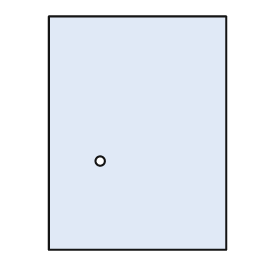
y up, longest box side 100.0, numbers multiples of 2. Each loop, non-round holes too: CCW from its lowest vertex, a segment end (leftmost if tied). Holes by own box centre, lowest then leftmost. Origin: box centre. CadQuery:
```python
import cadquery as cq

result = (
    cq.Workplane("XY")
    .moveTo(-38.0, -50.0)
    .lineTo(38.0, -50.0)
    .lineTo(38.0, 50.0)
    .lineTo(-38.0, 50.0)
    .close()
    .moveTo(-16.0, -12.0)
    .circle(2.0)
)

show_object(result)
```